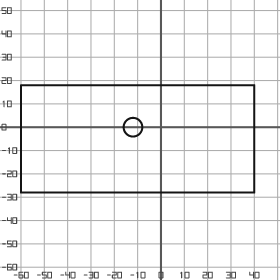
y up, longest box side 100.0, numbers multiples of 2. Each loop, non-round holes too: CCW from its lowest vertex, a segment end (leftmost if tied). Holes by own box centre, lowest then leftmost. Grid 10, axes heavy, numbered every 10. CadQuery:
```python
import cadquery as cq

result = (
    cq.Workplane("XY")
    .moveTo(-60.0, -28.0)
    .lineTo(40.0, -28.0)
    .lineTo(40.0, 18.0)
    .lineTo(-60.0, 18.0)
    .close()
    .moveTo(-12.0, 0.0)
    .circle(4.0)
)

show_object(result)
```